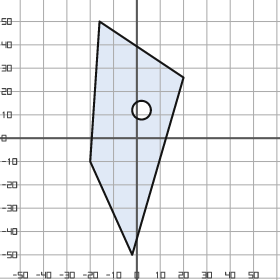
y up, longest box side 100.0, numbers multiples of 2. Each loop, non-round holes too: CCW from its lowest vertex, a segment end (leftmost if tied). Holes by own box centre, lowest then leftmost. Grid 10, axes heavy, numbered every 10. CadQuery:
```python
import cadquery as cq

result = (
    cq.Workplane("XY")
    .moveTo(-2.0, -50.0)
    .lineTo(20.0, 26.0)
    .lineTo(-16.0, 50.0)
    .lineTo(-20.0, -10.0)
    .close()
    .moveTo(2.0, 12.0)
    .circle(4.0)
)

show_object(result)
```